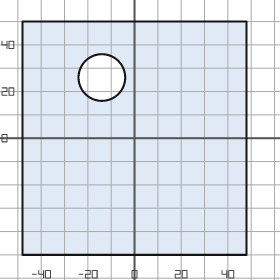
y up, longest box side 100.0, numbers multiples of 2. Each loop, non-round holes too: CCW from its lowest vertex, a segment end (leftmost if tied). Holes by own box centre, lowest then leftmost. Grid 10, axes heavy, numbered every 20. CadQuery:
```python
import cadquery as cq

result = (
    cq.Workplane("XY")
    .moveTo(-48.0, -50.0)
    .lineTo(48.0, -50.0)
    .lineTo(48.0, 50.0)
    .lineTo(-48.0, 50.0)
    .close()
    .moveTo(-14.0, 26.0)
    .circle(10.0)
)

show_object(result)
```